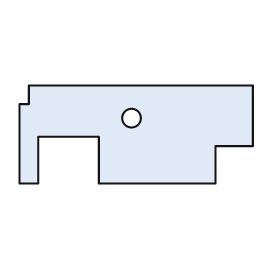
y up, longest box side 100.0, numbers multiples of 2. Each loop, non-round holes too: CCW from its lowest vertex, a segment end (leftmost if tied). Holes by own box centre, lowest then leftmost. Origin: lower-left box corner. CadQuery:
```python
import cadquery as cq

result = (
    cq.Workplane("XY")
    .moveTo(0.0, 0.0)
    .lineTo(8.0, 0.0)
    .lineTo(8.0, 20.0)
    .lineTo(34.0, 20.0)
    .lineTo(34.0, 0.0)
    .lineTo(84.0, 0.0)
    .lineTo(84.0, 16.0)
    .lineTo(100.0, 16.0)
    .lineTo(100.0, 42.0)
    .lineTo(4.0, 42.0)
    .lineTo(4.0, 34.0)
    .lineTo(0.0, 34.0)
    .close()
    .moveTo(48.0, 28.0)
    .circle(4.0)
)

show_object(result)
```